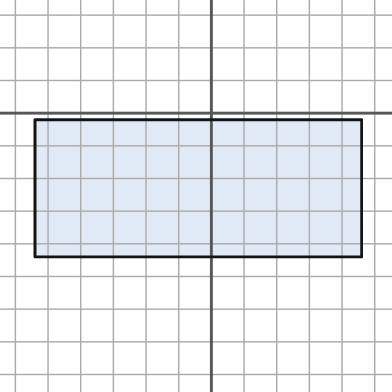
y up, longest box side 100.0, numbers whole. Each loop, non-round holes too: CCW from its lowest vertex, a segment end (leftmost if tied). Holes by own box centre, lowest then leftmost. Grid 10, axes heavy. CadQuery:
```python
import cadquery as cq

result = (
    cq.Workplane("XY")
    .moveTo(-54.0, -44.0)
    .lineTo(46.0, -44.0)
    .lineTo(46.0, -2.0)
    .lineTo(-54.0, -2.0)
    .close()
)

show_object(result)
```